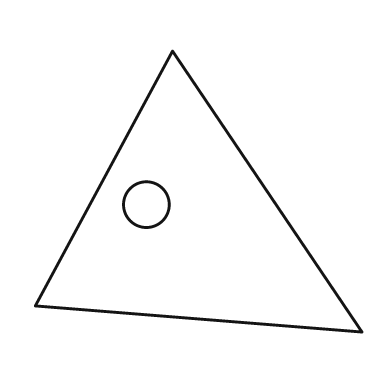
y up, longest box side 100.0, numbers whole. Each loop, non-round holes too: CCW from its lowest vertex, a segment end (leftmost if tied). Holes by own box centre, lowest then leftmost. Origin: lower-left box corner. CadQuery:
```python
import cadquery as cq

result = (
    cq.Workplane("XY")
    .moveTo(100.0, 0.0)
    .lineTo(42.0, 86.0)
    .lineTo(0.0, 8.0)
    .close()
    .moveTo(34.0, 39.0)
    .circle(7.0)
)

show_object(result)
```